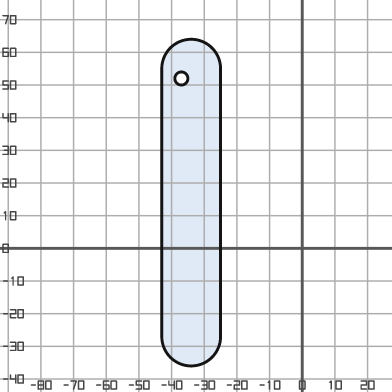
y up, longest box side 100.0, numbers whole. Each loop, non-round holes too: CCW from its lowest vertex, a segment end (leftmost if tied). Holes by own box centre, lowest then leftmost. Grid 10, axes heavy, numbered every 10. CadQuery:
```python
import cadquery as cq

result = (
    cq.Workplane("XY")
    .moveTo(-43.0, -27.0)
    .threePointArc((-34.0, -36.0), (-25.0, -27.0))
    .lineTo(-25.0, 55.0)
    .threePointArc((-34.0, 64.0), (-43.0, 55.0))
    .close()
    .moveTo(-37.0, 52.0)
    .circle(2.0)
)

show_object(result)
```